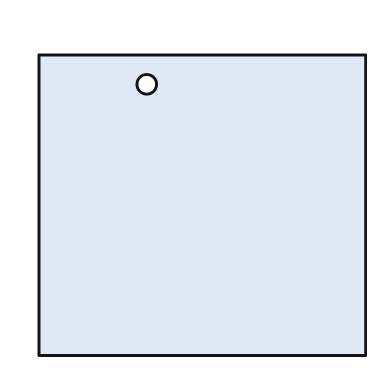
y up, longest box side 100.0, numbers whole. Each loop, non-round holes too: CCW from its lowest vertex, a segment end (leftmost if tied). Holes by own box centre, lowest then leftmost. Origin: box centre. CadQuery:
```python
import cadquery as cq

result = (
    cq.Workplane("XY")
    .moveTo(-50.0, -46.0)
    .lineTo(50.0, -46.0)
    .lineTo(50.0, 46.0)
    .lineTo(-50.0, 46.0)
    .close()
    .moveTo(-17.0, 37.0)
    .circle(3.0)
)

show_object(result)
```